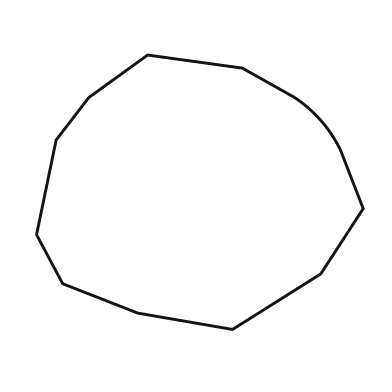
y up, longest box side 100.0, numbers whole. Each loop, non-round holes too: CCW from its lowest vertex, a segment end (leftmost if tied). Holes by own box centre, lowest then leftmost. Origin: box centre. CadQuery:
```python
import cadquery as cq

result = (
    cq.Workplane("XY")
    .moveTo(10.0, -42.0)
    .lineTo(37.0, -25.0)
    .lineTo(50.0, -5.0)
    .lineTo(43.0, 13.0)
    .threePointArc((37.0, 22.0), (29.0, 29.0))
    .lineTo(13.0, 38.0)
    .lineTo(-16.0, 42.0)
    .lineTo(-34.0, 29.0)
    .lineTo(-44.0, 16.0)
    .lineTo(-50.0, -13.0)
    .lineTo(-42.0, -28.0)
    .lineTo(-19.0, -37.0)
    .close()
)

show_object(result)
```